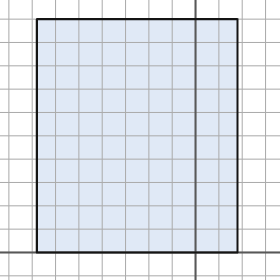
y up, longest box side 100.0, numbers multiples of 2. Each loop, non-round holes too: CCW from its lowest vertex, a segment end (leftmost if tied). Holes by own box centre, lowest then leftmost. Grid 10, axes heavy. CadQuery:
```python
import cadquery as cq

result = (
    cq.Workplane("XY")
    .moveTo(-68.0, 0.0)
    .lineTo(18.0, 0.0)
    .lineTo(18.0, 100.0)
    .lineTo(-68.0, 100.0)
    .close()
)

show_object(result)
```